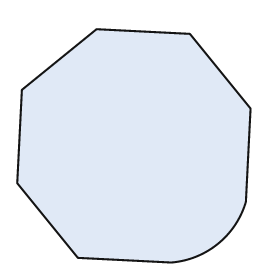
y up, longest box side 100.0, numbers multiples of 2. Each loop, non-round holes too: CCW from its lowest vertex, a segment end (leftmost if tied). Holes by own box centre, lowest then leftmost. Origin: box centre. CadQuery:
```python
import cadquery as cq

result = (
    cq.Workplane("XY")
    .moveTo(16.0, -50.0)
    .threePointArc((36.0, -42.0), (48.0, -24.0))
    .lineTo(50.0, 16.0)
    .lineTo(24.0, 48.0)
    .lineTo(-16.0, 50.0)
    .lineTo(-48.0, 24.0)
    .lineTo(-50.0, -16.0)
    .lineTo(-24.0, -48.0)
    .close()
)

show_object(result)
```